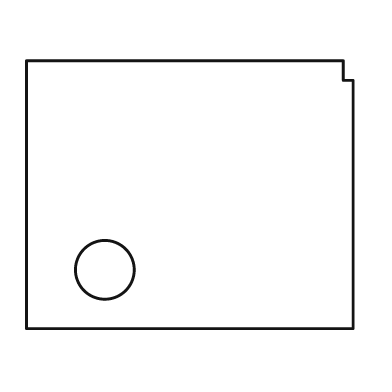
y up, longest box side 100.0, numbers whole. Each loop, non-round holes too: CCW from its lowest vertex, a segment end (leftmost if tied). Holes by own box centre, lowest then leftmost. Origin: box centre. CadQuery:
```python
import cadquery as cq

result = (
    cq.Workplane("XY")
    .moveTo(-50.0, -41.0)
    .lineTo(50.0, -41.0)
    .lineTo(50.0, 35.0)
    .lineTo(47.0, 35.0)
    .lineTo(47.0, 41.0)
    .lineTo(-50.0, 41.0)
    .close()
    .moveTo(-26.0, -23.0)
    .circle(9.0)
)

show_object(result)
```